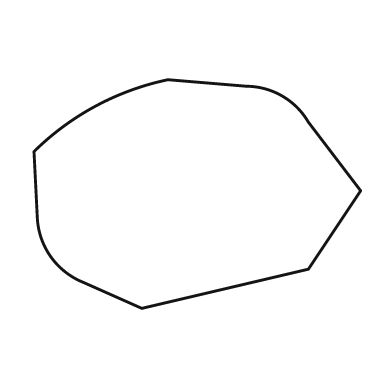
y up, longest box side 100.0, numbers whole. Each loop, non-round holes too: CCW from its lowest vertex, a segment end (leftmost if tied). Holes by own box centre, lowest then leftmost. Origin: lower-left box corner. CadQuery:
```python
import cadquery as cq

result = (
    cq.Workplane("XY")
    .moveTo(33.0, 0.0)
    .lineTo(84.0, 12.0)
    .lineTo(100.0, 36.0)
    .lineTo(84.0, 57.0)
    .threePointArc((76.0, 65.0), (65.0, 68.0))
    .lineTo(41.0, 70.0)
    .threePointArc((19.0, 62.0), (0.0, 48.0))
    .lineTo(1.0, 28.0)
    .threePointArc((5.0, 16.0), (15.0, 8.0))
    .close()
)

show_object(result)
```